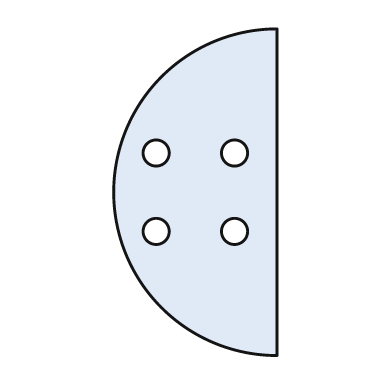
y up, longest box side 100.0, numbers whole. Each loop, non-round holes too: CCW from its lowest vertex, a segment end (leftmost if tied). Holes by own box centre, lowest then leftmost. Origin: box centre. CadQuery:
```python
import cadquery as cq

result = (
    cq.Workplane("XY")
    .moveTo(25.0, -50.0)
    .lineTo(25.0, 50.0)
    .threePointArc((-25.0, 0.0), (25.0, -50.0))
    .close()
    .moveTo(-12.0, -12.0)
    .circle(4.0)
    .moveTo(12.0, -12.0)
    .circle(4.0)
    .moveTo(-12.0, 12.0)
    .circle(4.0)
    .moveTo(12.0, 12.0)
    .circle(4.0)
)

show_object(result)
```